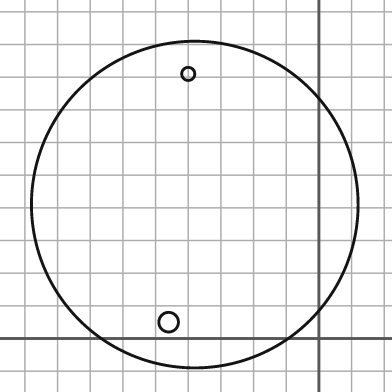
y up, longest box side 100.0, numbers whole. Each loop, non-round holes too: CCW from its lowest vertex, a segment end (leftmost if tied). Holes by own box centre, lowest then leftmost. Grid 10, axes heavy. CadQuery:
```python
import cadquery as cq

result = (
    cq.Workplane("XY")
    .moveTo(-38.0, 41.0)
    .circle(50.0)
    .moveTo(-46.0, 5.0)
    .circle(3.0)
    .moveTo(-40.0, 81.0)
    .circle(2.0)
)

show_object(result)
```